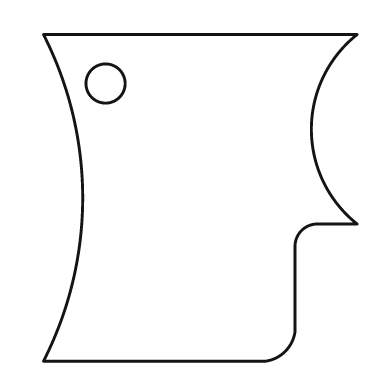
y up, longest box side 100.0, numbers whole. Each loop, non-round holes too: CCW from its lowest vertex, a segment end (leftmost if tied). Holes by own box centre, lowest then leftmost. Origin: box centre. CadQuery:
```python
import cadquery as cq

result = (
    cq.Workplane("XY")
    .moveTo(-48.0, -50.0)
    .lineTo(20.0, -50.0)
    .threePointArc((26.0, -47.0), (29.0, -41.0))
    .lineTo(29.0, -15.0)
    .threePointArc((31.0, -10.0), (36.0, -8.0))
    .lineTo(48.0, -8.0)
    .threePointArc((34.0, 21.0), (48.0, 50.0))
    .lineTo(-48.0, 50.0)
    .threePointArc((-36.0, 0.0), (-48.0, -50.0))
    .close()
    .moveTo(-29.0, 35.0)
    .circle(6.0)
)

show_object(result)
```